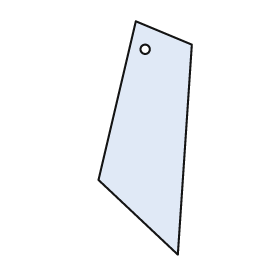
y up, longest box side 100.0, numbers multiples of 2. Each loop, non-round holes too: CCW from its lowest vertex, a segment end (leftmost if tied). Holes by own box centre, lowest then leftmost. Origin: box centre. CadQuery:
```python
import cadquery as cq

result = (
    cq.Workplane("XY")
    .moveTo(14.0, -50.0)
    .lineTo(20.0, 40.0)
    .lineTo(-4.0, 50.0)
    .lineTo(-20.0, -18.0)
    .close()
    .moveTo(0.0, 38.0)
    .circle(2.0)
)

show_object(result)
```